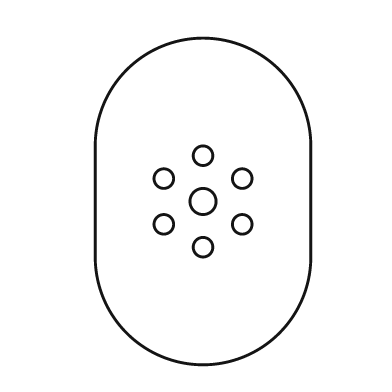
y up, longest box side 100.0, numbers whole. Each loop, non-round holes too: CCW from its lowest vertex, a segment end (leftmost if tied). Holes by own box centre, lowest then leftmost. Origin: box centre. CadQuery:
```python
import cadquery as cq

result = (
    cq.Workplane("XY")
    .moveTo(-33.0, -17.0)
    .threePointArc((0.0, -50.0), (33.0, -17.0))
    .lineTo(33.0, 17.0)
    .threePointArc((0.0, 50.0), (-33.0, 17.0))
    .close()
    .moveTo(0.0, -14.0)
    .circle(3.0)
    .moveTo(-12.0, -7.0)
    .circle(3.0)
    .moveTo(12.0, -7.0)
    .circle(3.0)
    .moveTo(0.0, 0.0)
    .circle(4.0)
    .moveTo(-12.0, 7.0)
    .circle(3.0)
    .moveTo(12.0, 7.0)
    .circle(3.0)
    .moveTo(0.0, 14.0)
    .circle(3.0)
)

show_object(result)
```